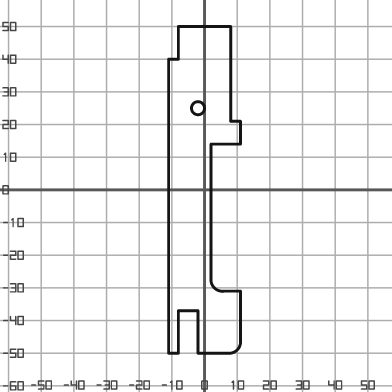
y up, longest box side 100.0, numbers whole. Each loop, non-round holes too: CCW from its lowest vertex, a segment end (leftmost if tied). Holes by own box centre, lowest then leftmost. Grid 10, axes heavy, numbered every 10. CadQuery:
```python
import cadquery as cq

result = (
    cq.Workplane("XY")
    .moveTo(-11.0, -50.0)
    .lineTo(-8.0, -50.0)
    .lineTo(-8.0, -37.0)
    .lineTo(-2.0, -37.0)
    .lineTo(-2.0, -50.0)
    .lineTo(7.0, -50.0)
    .threePointArc((10.0, -49.0), (11.0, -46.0))
    .lineTo(11.0, -31.0)
    .lineTo(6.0, -31.0)
    .threePointArc((3.0, -30.0), (2.0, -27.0))
    .lineTo(2.0, 14.0)
    .lineTo(11.0, 14.0)
    .lineTo(11.0, 21.0)
    .lineTo(8.0, 21.0)
    .lineTo(8.0, 50.0)
    .lineTo(-8.0, 50.0)
    .lineTo(-8.0, 40.0)
    .lineTo(-11.0, 40.0)
    .close()
    .moveTo(-2.0, 25.0)
    .circle(2.0)
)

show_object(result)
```